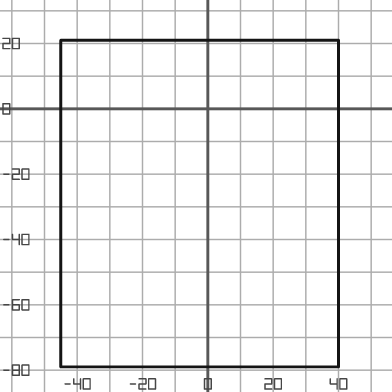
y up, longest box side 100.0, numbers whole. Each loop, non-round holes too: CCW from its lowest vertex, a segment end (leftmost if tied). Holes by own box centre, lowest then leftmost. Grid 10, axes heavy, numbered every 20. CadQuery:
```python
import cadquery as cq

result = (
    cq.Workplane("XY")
    .moveTo(-45.0, -79.0)
    .lineTo(40.0, -79.0)
    .lineTo(40.0, 21.0)
    .lineTo(-45.0, 21.0)
    .close()
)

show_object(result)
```